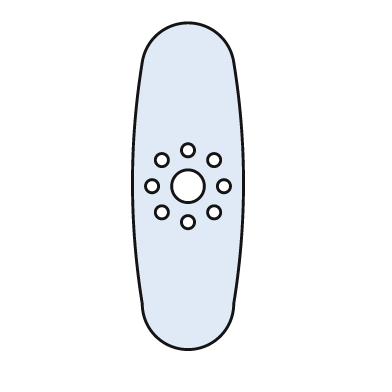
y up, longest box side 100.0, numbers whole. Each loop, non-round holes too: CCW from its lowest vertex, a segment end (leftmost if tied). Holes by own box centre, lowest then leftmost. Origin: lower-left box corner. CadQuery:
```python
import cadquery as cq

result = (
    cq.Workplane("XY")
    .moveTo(3.0, 14.0)
    .threePointArc((17.0, 0.0), (31.0, 14.0))
    .threePointArc((34.0, 51.0), (31.0, 88.0))
    .threePointArc((17.0, 100.0), (3.0, 88.0))
    .threePointArc((0.0, 51.0), (3.0, 14.0))
    .close()
    .moveTo(17.0, 39.0)
    .circle(2.0)
    .moveTo(9.0, 42.0)
    .circle(2.0)
    .moveTo(25.0, 42.0)
    .circle(2.0)
    .moveTo(6.0, 50.0)
    .circle(2.0)
    .moveTo(17.0, 50.0)
    .circle(5.0)
    .moveTo(28.0, 50.0)
    .circle(2.0)
    .moveTo(9.0, 58.0)
    .circle(2.0)
    .moveTo(25.0, 58.0)
    .circle(2.0)
    .moveTo(17.0, 61.0)
    .circle(2.0)
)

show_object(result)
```